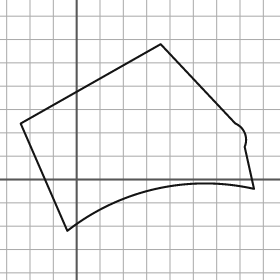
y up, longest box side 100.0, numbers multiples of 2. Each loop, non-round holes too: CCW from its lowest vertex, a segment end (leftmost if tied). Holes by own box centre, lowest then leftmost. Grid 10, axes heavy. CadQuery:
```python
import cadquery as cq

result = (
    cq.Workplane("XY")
    .moveTo(-4.0, -22.0)
    .threePointArc((34.0, -4.0), (76.0, -4.0))
    .lineTo(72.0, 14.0)
    .threePointArc((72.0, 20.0), (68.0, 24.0))
    .lineTo(36.0, 58.0)
    .lineTo(-24.0, 24.0)
    .close()
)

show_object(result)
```